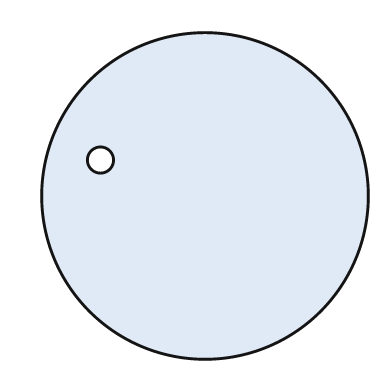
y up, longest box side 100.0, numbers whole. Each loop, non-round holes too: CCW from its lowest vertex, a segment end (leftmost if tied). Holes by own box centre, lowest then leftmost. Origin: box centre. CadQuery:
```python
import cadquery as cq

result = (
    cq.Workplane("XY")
    .moveTo(0.0, 0.0)
    .circle(50.0)
    .moveTo(-32.0, 11.0)
    .circle(4.0)
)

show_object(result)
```